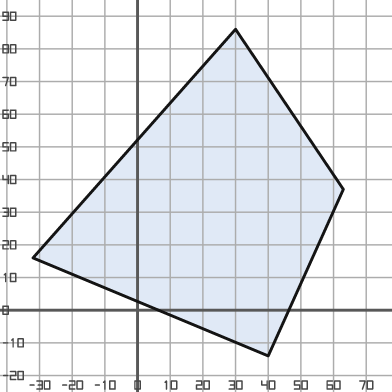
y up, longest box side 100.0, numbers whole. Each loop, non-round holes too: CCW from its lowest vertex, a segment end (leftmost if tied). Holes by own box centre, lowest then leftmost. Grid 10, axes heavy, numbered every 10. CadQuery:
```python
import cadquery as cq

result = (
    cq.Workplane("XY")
    .moveTo(40.0, -14.0)
    .lineTo(63.0, 37.0)
    .lineTo(30.0, 86.0)
    .lineTo(-32.0, 16.0)
    .close()
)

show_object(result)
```